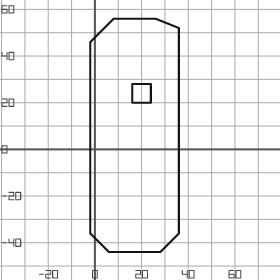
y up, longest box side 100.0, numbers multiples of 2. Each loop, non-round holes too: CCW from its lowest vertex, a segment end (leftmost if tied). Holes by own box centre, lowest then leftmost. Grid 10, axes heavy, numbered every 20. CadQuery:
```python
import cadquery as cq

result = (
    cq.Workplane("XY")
    .moveTo(6.0, -44.0)
    .lineTo(28.0, -44.0)
    .lineTo(36.0, -36.0)
    .lineTo(36.0, 52.0)
    .lineTo(26.0, 56.0)
    .lineTo(8.0, 56.0)
    .lineTo(-2.0, 46.0)
    .lineTo(-2.0, -36.0)
    .close()
    .moveTo(16.0, 20.0)
    .lineTo(24.0, 20.0)
    .lineTo(24.0, 28.0)
    .lineTo(16.0, 28.0)
    .close()
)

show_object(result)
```